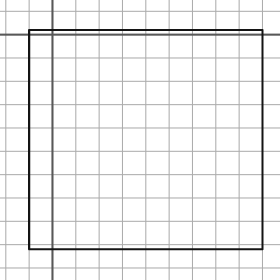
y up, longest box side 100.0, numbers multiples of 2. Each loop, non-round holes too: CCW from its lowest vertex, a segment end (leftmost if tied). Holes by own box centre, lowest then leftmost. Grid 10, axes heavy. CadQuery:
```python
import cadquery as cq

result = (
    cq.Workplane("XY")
    .moveTo(-10.0, -92.0)
    .lineTo(90.0, -92.0)
    .lineTo(90.0, 2.0)
    .lineTo(-10.0, 2.0)
    .close()
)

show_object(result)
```